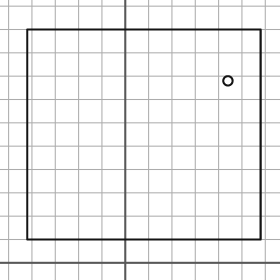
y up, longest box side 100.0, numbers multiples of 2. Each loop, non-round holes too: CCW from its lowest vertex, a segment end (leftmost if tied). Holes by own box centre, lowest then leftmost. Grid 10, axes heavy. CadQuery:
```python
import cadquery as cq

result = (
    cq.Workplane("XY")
    .moveTo(-42.0, 10.0)
    .lineTo(58.0, 10.0)
    .lineTo(58.0, 100.0)
    .lineTo(-42.0, 100.0)
    .close()
    .moveTo(44.0, 78.0)
    .circle(2.0)
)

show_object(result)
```